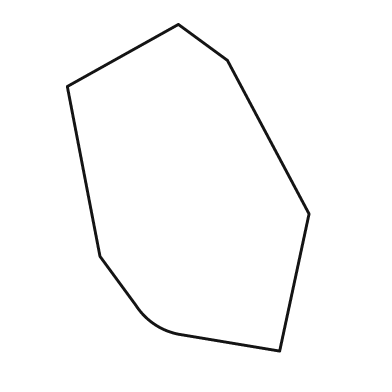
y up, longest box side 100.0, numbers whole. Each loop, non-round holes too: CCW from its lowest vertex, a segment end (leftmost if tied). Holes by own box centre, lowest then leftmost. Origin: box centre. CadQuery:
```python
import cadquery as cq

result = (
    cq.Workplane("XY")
    .moveTo(28.0, -50.0)
    .lineTo(37.0, -8.0)
    .lineTo(12.0, 39.0)
    .lineTo(-3.0, 50.0)
    .lineTo(-37.0, 31.0)
    .lineTo(-27.0, -21.0)
    .lineTo(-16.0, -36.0)
    .threePointArc((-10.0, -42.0), (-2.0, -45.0))
    .close()
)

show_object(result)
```